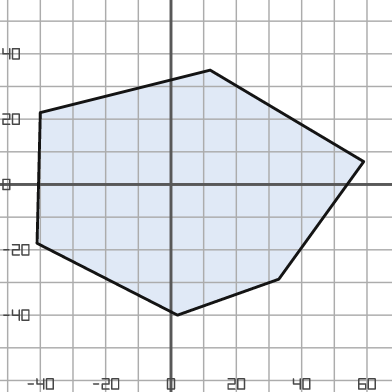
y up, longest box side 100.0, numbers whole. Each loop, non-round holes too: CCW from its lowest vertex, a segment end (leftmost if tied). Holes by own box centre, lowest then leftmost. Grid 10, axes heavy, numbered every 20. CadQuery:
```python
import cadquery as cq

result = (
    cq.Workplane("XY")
    .moveTo(2.0, -40.0)
    .lineTo(33.0, -29.0)
    .lineTo(59.0, 7.0)
    .lineTo(12.0, 35.0)
    .lineTo(-40.0, 22.0)
    .lineTo(-41.0, -18.0)
    .close()
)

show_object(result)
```